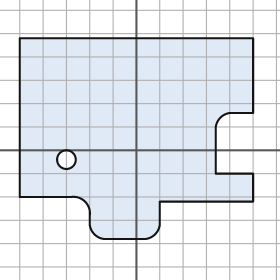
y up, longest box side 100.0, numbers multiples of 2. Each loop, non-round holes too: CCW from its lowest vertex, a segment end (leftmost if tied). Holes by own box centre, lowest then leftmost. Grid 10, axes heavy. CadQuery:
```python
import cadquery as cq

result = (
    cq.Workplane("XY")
    .moveTo(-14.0, -38.0)
    .lineTo(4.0, -38.0)
    .threePointArc((8.0, -36.0), (10.0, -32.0))
    .lineTo(10.0, -22.0)
    .lineTo(50.0, -22.0)
    .lineTo(50.0, -10.0)
    .lineTo(34.0, -10.0)
    .lineTo(34.0, 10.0)
    .threePointArc((36.0, 14.0), (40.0, 16.0))
    .lineTo(50.0, 16.0)
    .lineTo(50.0, 48.0)
    .lineTo(-50.0, 48.0)
    .lineTo(-50.0, -20.0)
    .lineTo(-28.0, -20.0)
    .threePointArc((-22.0, -22.0), (-20.0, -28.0))
    .lineTo(-20.0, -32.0)
    .threePointArc((-18.0, -36.0), (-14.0, -38.0))
    .close()
    .moveTo(-30.0, -4.0)
    .circle(4.0)
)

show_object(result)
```